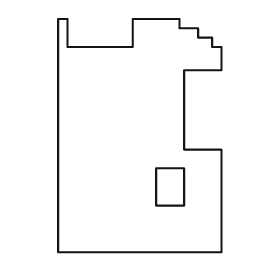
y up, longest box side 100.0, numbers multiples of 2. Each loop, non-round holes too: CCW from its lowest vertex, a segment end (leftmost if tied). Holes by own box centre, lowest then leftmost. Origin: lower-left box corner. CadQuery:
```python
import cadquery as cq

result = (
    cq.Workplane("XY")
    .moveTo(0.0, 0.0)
    .lineTo(70.0, 0.0)
    .lineTo(70.0, 44.0)
    .lineTo(54.0, 44.0)
    .lineTo(54.0, 78.0)
    .lineTo(70.0, 78.0)
    .lineTo(70.0, 88.0)
    .lineTo(66.0, 88.0)
    .lineTo(66.0, 92.0)
    .lineTo(60.0, 92.0)
    .lineTo(60.0, 96.0)
    .lineTo(52.0, 96.0)
    .lineTo(52.0, 100.0)
    .lineTo(32.0, 100.0)
    .lineTo(32.0, 88.0)
    .lineTo(4.0, 88.0)
    .lineTo(4.0, 100.0)
    .lineTo(0.0, 100.0)
    .close()
    .moveTo(42.0, 20.0)
    .lineTo(54.0, 20.0)
    .lineTo(54.0, 36.0)
    .lineTo(42.0, 36.0)
    .close()
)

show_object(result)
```